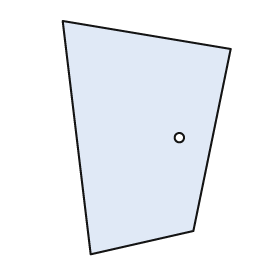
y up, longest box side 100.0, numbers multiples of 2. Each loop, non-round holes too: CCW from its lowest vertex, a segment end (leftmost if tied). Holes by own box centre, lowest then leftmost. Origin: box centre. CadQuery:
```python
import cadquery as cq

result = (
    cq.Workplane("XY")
    .moveTo(-24.0, -50.0)
    .lineTo(20.0, -40.0)
    .lineTo(36.0, 38.0)
    .lineTo(-36.0, 50.0)
    .close()
    .moveTo(14.0, 0.0)
    .circle(2.0)
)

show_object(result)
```